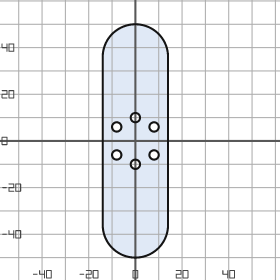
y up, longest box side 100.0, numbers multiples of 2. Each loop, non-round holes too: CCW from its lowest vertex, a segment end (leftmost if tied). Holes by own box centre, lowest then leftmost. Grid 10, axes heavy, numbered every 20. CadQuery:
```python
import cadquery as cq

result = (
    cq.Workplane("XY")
    .moveTo(-14.0, -36.0)
    .threePointArc((0.0, -50.0), (14.0, -36.0))
    .lineTo(14.0, 36.0)
    .threePointArc((0.0, 50.0), (-14.0, 36.0))
    .close()
    .moveTo(0.0, -10.0)
    .circle(2.0)
    .moveTo(-8.0, -6.0)
    .circle(2.0)
    .moveTo(8.0, -6.0)
    .circle(2.0)
    .moveTo(-8.0, 6.0)
    .circle(2.0)
    .moveTo(8.0, 6.0)
    .circle(2.0)
    .moveTo(0.0, 10.0)
    .circle(2.0)
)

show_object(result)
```